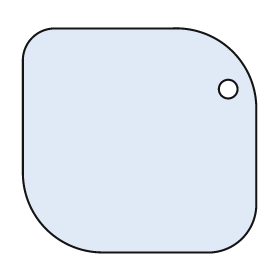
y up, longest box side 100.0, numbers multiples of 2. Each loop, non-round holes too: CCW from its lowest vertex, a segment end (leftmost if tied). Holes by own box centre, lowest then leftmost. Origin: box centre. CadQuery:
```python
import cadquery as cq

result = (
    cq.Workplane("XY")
    .moveTo(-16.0, -48.0)
    .lineTo(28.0, -48.0)
    .threePointArc((44.0, -42.0), (50.0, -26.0))
    .lineTo(50.0, 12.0)
    .threePointArc((40.0, 38.0), (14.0, 48.0))
    .lineTo(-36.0, 48.0)
    .threePointArc((-46.0, 44.0), (-50.0, 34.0))
    .lineTo(-50.0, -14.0)
    .threePointArc((-40.0, -38.0), (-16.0, -48.0))
    .close()
    .moveTo(38.0, 22.0)
    .circle(4.0)
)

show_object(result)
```